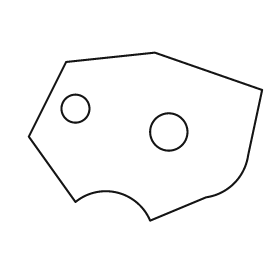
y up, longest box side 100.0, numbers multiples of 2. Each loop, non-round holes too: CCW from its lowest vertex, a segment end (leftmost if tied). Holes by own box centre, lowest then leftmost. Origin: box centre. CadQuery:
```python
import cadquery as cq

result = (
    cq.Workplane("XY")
    .moveTo(2.0, -36.0)
    .lineTo(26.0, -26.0)
    .threePointArc((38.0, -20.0), (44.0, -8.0))
    .lineTo(50.0, 20.0)
    .lineTo(4.0, 36.0)
    .lineTo(-34.0, 32.0)
    .lineTo(-50.0, 0.0)
    .lineTo(-30.0, -28.0)
    .threePointArc((-12.0, -24.0), (2.0, -36.0))
    .close()
    .moveTo(10.0, 2.0)
    .circle(8.0)
    .moveTo(-30.0, 12.0)
    .circle(6.0)
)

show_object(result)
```